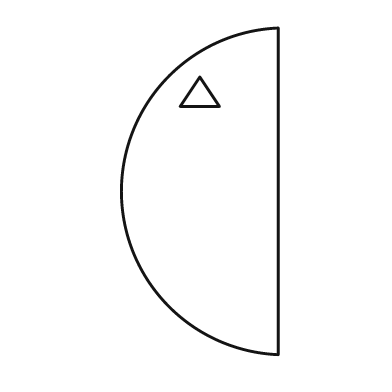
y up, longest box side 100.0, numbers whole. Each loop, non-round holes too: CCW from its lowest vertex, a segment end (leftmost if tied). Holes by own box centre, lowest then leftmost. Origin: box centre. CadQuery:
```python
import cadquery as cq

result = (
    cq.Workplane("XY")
    .moveTo(24.0, -50.0)
    .lineTo(24.0, 50.0)
    .threePointArc((-24.0, 0.0), (24.0, -50.0))
    .close()
    .moveTo(-6.0, 26.0)
    .lineTo(6.0, 26.0)
    .lineTo(0.0, 35.0)
    .close()
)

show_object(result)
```